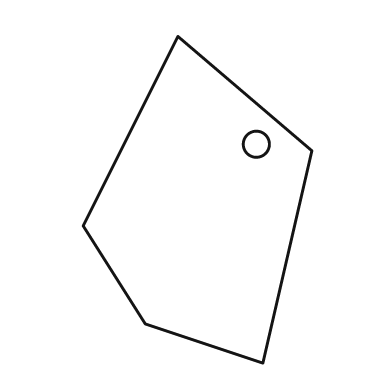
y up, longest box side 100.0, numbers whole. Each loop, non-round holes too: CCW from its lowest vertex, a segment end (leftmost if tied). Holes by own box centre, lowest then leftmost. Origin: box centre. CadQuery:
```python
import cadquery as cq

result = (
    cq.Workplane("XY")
    .moveTo(20.0, -50.0)
    .lineTo(35.0, 15.0)
    .lineTo(-6.0, 50.0)
    .lineTo(-35.0, -8.0)
    .lineTo(-16.0, -38.0)
    .close()
    .moveTo(18.0, 17.0)
    .circle(4.0)
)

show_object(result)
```